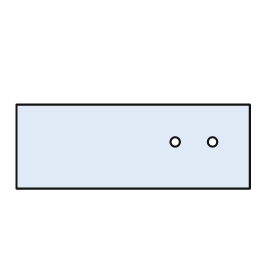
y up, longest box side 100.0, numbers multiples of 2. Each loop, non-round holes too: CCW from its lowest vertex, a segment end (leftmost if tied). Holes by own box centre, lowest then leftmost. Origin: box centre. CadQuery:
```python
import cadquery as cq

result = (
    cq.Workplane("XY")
    .moveTo(-50.0, -18.0)
    .lineTo(50.0, -18.0)
    .lineTo(50.0, 18.0)
    .lineTo(-50.0, 18.0)
    .close()
    .moveTo(18.0, 2.0)
    .circle(2.0)
    .moveTo(34.0, 2.0)
    .circle(2.0)
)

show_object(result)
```